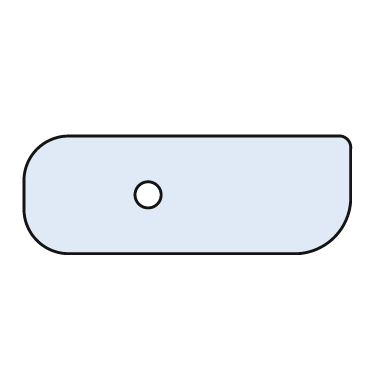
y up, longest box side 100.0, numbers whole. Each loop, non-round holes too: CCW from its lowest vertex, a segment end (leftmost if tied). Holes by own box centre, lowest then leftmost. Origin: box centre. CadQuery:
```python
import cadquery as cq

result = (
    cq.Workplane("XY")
    .moveTo(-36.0, -18.0)
    .lineTo(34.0, -18.0)
    .threePointArc((45.0, -13.0), (50.0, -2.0))
    .lineTo(50.0, 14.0)
    .threePointArc((49.0, 17.0), (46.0, 18.0))
    .lineTo(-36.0, 18.0)
    .threePointArc((-46.0, 14.0), (-50.0, 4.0))
    .lineTo(-50.0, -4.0)
    .threePointArc((-46.0, -14.0), (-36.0, -18.0))
    .close()
    .moveTo(-12.0, 0.0)
    .circle(4.0)
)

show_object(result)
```